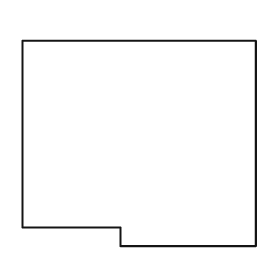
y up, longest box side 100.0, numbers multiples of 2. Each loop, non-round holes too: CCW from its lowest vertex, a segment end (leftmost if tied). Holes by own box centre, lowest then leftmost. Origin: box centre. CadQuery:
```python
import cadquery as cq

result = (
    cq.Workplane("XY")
    .moveTo(-8.0, -44.0)
    .lineTo(50.0, -44.0)
    .lineTo(50.0, 44.0)
    .lineTo(-50.0, 44.0)
    .lineTo(-50.0, -36.0)
    .lineTo(-8.0, -36.0)
    .close()
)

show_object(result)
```